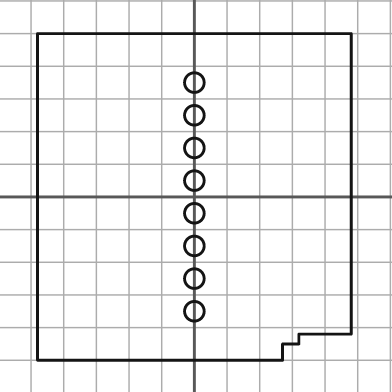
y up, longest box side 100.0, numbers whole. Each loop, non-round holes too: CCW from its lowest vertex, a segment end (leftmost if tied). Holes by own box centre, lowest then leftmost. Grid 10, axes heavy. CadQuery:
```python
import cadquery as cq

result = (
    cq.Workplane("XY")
    .moveTo(-48.0, -50.0)
    .lineTo(27.0, -50.0)
    .lineTo(27.0, -45.0)
    .lineTo(32.0, -45.0)
    .lineTo(32.0, -42.0)
    .lineTo(48.0, -42.0)
    .lineTo(48.0, 50.0)
    .lineTo(-48.0, 50.0)
    .close()
    .moveTo(0.0, -35.0)
    .circle(3.0)
    .moveTo(0.0, -25.0)
    .circle(3.0)
    .moveTo(0.0, -15.0)
    .circle(3.0)
    .moveTo(0.0, -5.0)
    .circle(3.0)
    .moveTo(0.0, 5.0)
    .circle(3.0)
    .moveTo(0.0, 15.0)
    .circle(3.0)
    .moveTo(0.0, 25.0)
    .circle(3.0)
    .moveTo(0.0, 35.0)
    .circle(3.0)
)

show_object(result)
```